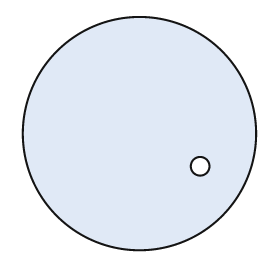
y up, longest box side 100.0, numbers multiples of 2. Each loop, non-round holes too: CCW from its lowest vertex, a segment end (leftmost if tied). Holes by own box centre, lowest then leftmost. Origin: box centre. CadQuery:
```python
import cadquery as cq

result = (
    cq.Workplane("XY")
    .moveTo(0.0, 0.0)
    .circle(50.0)
    .moveTo(26.0, -14.0)
    .circle(4.0)
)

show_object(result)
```